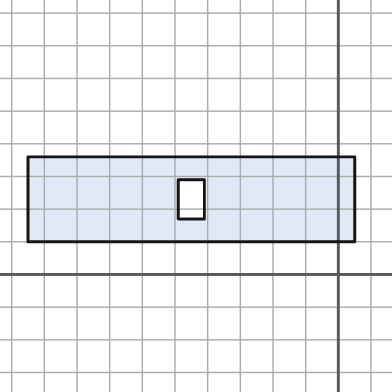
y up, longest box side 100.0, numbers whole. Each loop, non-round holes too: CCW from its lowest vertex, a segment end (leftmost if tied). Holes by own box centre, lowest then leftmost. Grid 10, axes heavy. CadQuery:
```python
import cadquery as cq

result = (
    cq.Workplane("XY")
    .moveTo(-95.0, 10.0)
    .lineTo(5.0, 10.0)
    .lineTo(5.0, 36.0)
    .lineTo(-95.0, 36.0)
    .close()
    .moveTo(-49.0, 17.0)
    .lineTo(-41.0, 17.0)
    .lineTo(-41.0, 29.0)
    .lineTo(-49.0, 29.0)
    .close()
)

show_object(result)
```